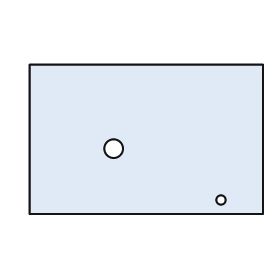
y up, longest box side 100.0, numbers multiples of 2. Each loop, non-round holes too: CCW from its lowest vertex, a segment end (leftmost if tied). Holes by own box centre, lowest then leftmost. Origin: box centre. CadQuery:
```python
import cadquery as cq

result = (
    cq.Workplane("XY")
    .moveTo(-50.0, -32.0)
    .lineTo(50.0, -32.0)
    .lineTo(50.0, 32.0)
    .lineTo(-50.0, 32.0)
    .close()
    .moveTo(32.0, -26.0)
    .circle(2.0)
    .moveTo(-14.0, -4.0)
    .circle(4.0)
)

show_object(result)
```